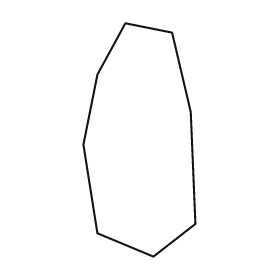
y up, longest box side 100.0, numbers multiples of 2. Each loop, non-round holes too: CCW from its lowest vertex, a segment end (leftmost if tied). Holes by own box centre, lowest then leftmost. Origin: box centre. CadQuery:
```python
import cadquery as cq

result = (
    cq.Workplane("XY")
    .moveTo(6.0, -50.0)
    .lineTo(24.0, -36.0)
    .lineTo(22.0, 12.0)
    .lineTo(14.0, 46.0)
    .lineTo(-6.0, 50.0)
    .lineTo(-18.0, 28.0)
    .lineTo(-24.0, -2.0)
    .lineTo(-18.0, -40.0)
    .close()
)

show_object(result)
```